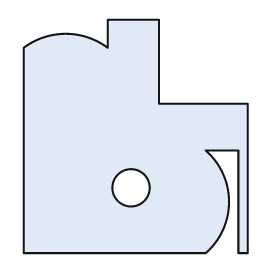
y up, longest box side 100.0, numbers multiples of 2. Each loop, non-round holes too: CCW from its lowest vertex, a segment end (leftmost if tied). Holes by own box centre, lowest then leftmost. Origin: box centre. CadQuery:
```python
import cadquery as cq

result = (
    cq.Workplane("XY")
    .moveTo(-48.0, -50.0)
    .lineTo(30.0, -50.0)
    .threePointArc((40.0, -28.0), (30.0, -6.0))
    .lineTo(44.0, -6.0)
    .lineTo(44.0, -50.0)
    .lineTo(48.0, -50.0)
    .lineTo(48.0, 14.0)
    .lineTo(10.0, 14.0)
    .lineTo(10.0, 50.0)
    .lineTo(-12.0, 50.0)
    .lineTo(-12.0, 38.0)
    .threePointArc((-30.0, 44.0), (-48.0, 38.0))
    .close()
    .moveTo(-2.0, -22.0)
    .circle(8.0)
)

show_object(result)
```